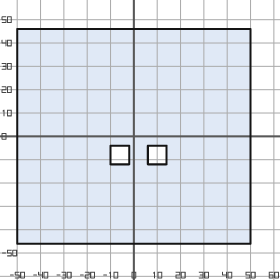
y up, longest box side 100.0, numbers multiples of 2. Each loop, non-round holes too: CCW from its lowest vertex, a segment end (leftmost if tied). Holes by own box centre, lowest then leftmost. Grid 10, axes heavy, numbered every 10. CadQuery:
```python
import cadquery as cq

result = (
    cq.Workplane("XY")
    .moveTo(-50.0, -46.0)
    .lineTo(50.0, -46.0)
    .lineTo(50.0, 46.0)
    .lineTo(-50.0, 46.0)
    .close()
    .moveTo(-10.0, -12.0)
    .lineTo(-2.0, -12.0)
    .lineTo(-2.0, -4.0)
    .lineTo(-10.0, -4.0)
    .close()
    .moveTo(6.0, -12.0)
    .lineTo(14.0, -12.0)
    .lineTo(14.0, -4.0)
    .lineTo(6.0, -4.0)
    .close()
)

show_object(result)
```